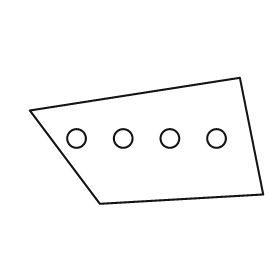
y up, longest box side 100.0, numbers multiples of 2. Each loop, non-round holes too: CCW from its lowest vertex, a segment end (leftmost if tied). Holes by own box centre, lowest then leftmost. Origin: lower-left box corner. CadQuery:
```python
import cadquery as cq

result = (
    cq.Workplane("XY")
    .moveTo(30.0, 0.0)
    .lineTo(100.0, 4.0)
    .lineTo(90.0, 54.0)
    .lineTo(0.0, 40.0)
    .close()
    .moveTo(20.0, 28.0)
    .circle(4.0)
    .moveTo(40.0, 28.0)
    .circle(4.0)
    .moveTo(60.0, 28.0)
    .circle(4.0)
    .moveTo(80.0, 28.0)
    .circle(4.0)
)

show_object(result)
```